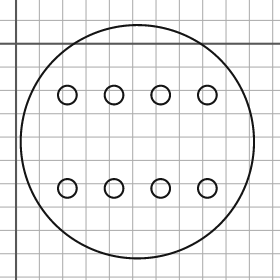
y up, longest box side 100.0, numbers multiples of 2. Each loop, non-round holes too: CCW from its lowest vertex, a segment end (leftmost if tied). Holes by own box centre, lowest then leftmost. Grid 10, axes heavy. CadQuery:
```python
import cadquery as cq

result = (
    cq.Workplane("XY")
    .moveTo(52.0, -42.0)
    .circle(50.0)
    .moveTo(22.0, -62.0)
    .circle(4.0)
    .moveTo(42.0, -62.0)
    .circle(4.0)
    .moveTo(62.0, -62.0)
    .circle(4.0)
    .moveTo(82.0, -62.0)
    .circle(4.0)
    .moveTo(22.0, -22.0)
    .circle(4.0)
    .moveTo(42.0, -22.0)
    .circle(4.0)
    .moveTo(62.0, -22.0)
    .circle(4.0)
    .moveTo(82.0, -22.0)
    .circle(4.0)
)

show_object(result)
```